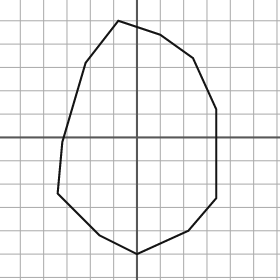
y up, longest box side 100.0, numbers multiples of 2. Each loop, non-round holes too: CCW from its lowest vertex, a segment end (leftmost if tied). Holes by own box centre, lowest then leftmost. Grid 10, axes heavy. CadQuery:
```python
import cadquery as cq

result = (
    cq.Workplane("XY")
    .moveTo(0.0, -50.0)
    .lineTo(22.0, -40.0)
    .lineTo(34.0, -26.0)
    .lineTo(34.0, 12.0)
    .lineTo(24.0, 34.0)
    .lineTo(10.0, 44.0)
    .lineTo(-8.0, 50.0)
    .lineTo(-22.0, 32.0)
    .lineTo(-32.0, -2.0)
    .lineTo(-34.0, -24.0)
    .lineTo(-16.0, -42.0)
    .close()
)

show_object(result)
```